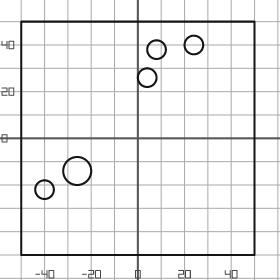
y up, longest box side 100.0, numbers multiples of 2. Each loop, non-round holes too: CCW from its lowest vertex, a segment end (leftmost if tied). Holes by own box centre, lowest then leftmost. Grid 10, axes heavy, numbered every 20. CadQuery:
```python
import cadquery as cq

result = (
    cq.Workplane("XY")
    .moveTo(-50.0, -50.0)
    .lineTo(50.0, -50.0)
    .lineTo(50.0, 50.0)
    .lineTo(-50.0, 50.0)
    .close()
    .moveTo(-40.0, -22.0)
    .circle(4.0)
    .moveTo(-26.0, -14.0)
    .circle(6.0)
    .moveTo(4.0, 26.0)
    .circle(4.0)
    .moveTo(8.0, 38.0)
    .circle(4.0)
    .moveTo(24.0, 40.0)
    .circle(4.0)
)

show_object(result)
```